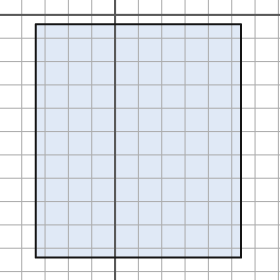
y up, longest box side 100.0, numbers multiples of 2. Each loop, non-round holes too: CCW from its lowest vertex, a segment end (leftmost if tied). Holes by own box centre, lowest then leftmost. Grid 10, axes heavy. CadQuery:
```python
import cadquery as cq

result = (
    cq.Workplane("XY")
    .moveTo(-34.0, -104.0)
    .lineTo(54.0, -104.0)
    .lineTo(54.0, -4.0)
    .lineTo(-34.0, -4.0)
    .close()
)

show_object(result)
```